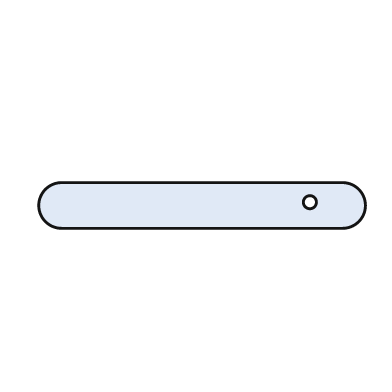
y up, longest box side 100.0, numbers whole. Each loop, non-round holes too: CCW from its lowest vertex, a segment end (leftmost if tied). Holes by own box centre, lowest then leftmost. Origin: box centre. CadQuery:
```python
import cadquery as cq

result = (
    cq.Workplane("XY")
    .moveTo(-43.0, -7.0)
    .lineTo(43.0, -7.0)
    .threePointArc((50.0, 0.0), (43.0, 7.0))
    .lineTo(-43.0, 7.0)
    .threePointArc((-50.0, 0.0), (-43.0, -7.0))
    .close()
    .moveTo(33.0, 1.0)
    .circle(2.0)
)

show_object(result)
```